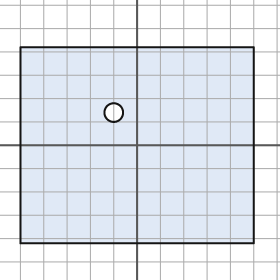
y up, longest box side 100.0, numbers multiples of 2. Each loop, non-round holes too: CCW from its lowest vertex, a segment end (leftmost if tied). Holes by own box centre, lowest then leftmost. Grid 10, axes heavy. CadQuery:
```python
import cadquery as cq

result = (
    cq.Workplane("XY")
    .moveTo(-50.0, -42.0)
    .lineTo(50.0, -42.0)
    .lineTo(50.0, 42.0)
    .lineTo(-50.0, 42.0)
    .close()
    .moveTo(-10.0, 14.0)
    .circle(4.0)
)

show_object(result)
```